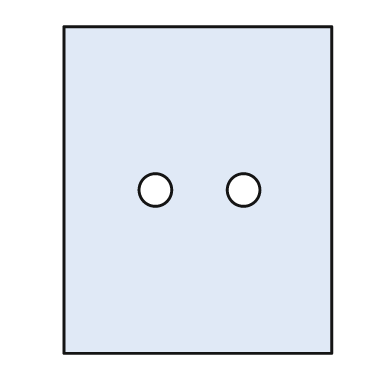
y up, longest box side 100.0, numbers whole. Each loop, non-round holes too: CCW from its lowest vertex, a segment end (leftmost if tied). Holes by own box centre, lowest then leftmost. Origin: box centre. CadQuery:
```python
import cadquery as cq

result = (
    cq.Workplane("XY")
    .moveTo(-41.0, -50.0)
    .lineTo(41.0, -50.0)
    .lineTo(41.0, 50.0)
    .lineTo(-41.0, 50.0)
    .close()
    .moveTo(-13.0, 0.0)
    .circle(5.0)
    .moveTo(14.0, 0.0)
    .circle(5.0)
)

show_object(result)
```